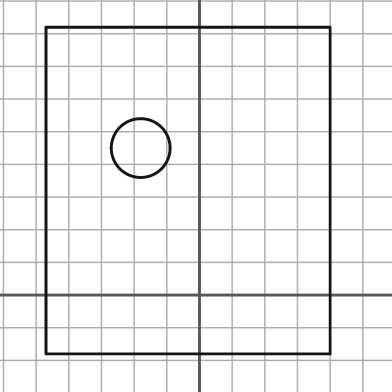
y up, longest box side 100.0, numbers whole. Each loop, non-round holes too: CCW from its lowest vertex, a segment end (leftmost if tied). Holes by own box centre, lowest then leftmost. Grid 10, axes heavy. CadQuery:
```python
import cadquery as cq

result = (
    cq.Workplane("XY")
    .moveTo(-47.0, -18.0)
    .lineTo(40.0, -18.0)
    .lineTo(40.0, 82.0)
    .lineTo(-47.0, 82.0)
    .close()
    .moveTo(-18.0, 45.0)
    .circle(9.0)
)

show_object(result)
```